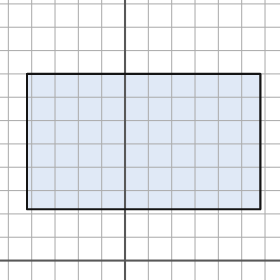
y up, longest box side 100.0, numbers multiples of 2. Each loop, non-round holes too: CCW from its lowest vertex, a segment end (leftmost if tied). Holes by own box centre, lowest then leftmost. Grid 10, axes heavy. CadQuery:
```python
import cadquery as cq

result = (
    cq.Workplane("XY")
    .moveTo(-42.0, 22.0)
    .lineTo(58.0, 22.0)
    .lineTo(58.0, 80.0)
    .lineTo(-42.0, 80.0)
    .close()
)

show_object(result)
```